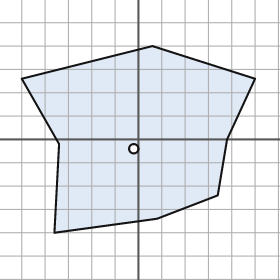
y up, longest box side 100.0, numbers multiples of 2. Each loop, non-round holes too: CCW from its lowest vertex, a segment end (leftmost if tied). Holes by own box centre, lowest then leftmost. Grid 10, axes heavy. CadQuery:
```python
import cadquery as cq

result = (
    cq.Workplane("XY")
    .moveTo(-36.0, -40.0)
    .lineTo(8.0, -34.0)
    .lineTo(34.0, -24.0)
    .lineTo(38.0, 0.0)
    .lineTo(50.0, 26.0)
    .lineTo(6.0, 40.0)
    .lineTo(-50.0, 26.0)
    .lineTo(-34.0, -2.0)
    .close()
    .moveTo(-2.0, -4.0)
    .circle(2.0)
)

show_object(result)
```